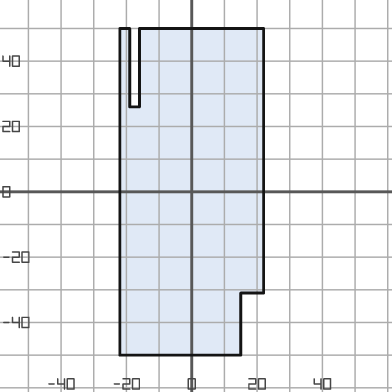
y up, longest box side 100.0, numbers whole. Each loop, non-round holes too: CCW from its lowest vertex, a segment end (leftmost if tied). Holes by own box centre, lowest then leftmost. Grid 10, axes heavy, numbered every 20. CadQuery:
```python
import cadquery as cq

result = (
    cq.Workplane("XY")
    .moveTo(-22.0, -50.0)
    .lineTo(15.0, -50.0)
    .lineTo(15.0, -31.0)
    .lineTo(22.0, -31.0)
    .lineTo(22.0, 50.0)
    .lineTo(-16.0, 50.0)
    .lineTo(-16.0, 26.0)
    .lineTo(-19.0, 26.0)
    .lineTo(-19.0, 50.0)
    .lineTo(-22.0, 50.0)
    .close()
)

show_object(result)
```